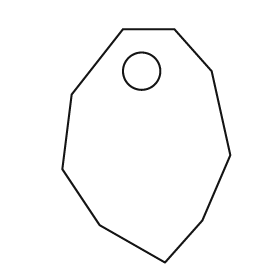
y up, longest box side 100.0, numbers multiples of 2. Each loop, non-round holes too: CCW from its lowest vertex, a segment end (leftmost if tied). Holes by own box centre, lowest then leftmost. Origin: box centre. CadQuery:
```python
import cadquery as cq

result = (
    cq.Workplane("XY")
    .moveTo(8.0, -50.0)
    .lineTo(24.0, -32.0)
    .lineTo(36.0, -4.0)
    .lineTo(28.0, 32.0)
    .lineTo(12.0, 50.0)
    .lineTo(-10.0, 50.0)
    .lineTo(-32.0, 22.0)
    .lineTo(-36.0, -10.0)
    .lineTo(-20.0, -34.0)
    .close()
    .moveTo(-2.0, 32.0)
    .circle(8.0)
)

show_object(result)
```